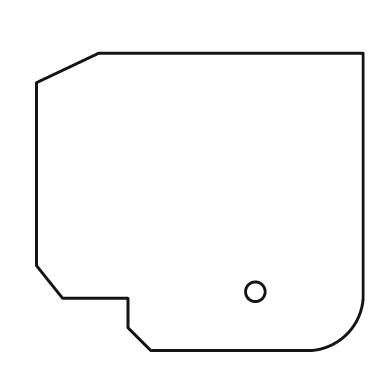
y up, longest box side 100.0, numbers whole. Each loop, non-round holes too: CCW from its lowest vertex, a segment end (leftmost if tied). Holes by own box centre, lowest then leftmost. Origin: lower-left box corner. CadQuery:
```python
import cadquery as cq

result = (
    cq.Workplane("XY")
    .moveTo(35.0, 0.0)
    .lineTo(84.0, 0.0)
    .threePointArc((95.0, 5.0), (100.0, 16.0))
    .lineTo(100.0, 91.0)
    .lineTo(19.0, 91.0)
    .lineTo(0.0, 82.0)
    .lineTo(0.0, 26.0)
    .lineTo(8.0, 16.0)
    .lineTo(28.0, 16.0)
    .lineTo(28.0, 7.0)
    .close()
    .moveTo(67.0, 18.0)
    .circle(3.0)
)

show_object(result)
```